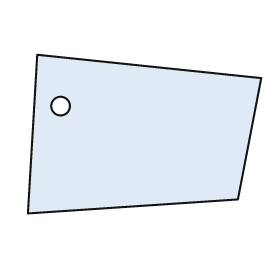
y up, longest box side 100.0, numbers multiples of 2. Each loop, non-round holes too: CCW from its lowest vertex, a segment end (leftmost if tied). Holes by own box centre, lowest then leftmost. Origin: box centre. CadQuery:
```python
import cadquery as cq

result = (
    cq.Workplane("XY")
    .moveTo(-50.0, -34.0)
    .lineTo(40.0, -28.0)
    .lineTo(50.0, 24.0)
    .lineTo(-46.0, 34.0)
    .close()
    .moveTo(-36.0, 12.0)
    .circle(4.0)
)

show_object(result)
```